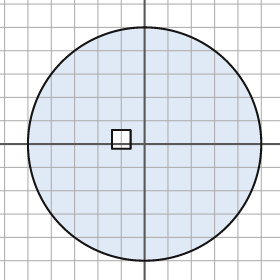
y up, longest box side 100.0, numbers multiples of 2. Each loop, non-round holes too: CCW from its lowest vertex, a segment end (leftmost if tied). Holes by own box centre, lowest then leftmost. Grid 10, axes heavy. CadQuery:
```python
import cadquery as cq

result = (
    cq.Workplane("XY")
    .moveTo(0.0, 0.0)
    .circle(50.0)
    .moveTo(-14.0, -2.0)
    .lineTo(-6.0, -2.0)
    .lineTo(-6.0, 6.0)
    .lineTo(-14.0, 6.0)
    .close()
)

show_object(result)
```